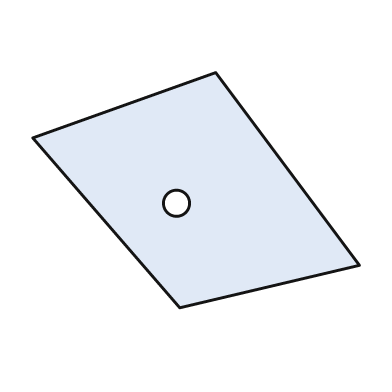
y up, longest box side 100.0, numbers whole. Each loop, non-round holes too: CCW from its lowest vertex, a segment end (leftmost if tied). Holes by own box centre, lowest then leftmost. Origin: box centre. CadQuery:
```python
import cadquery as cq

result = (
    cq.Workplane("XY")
    .moveTo(-5.0, -36.0)
    .lineTo(50.0, -23.0)
    .lineTo(6.0, 36.0)
    .lineTo(-50.0, 16.0)
    .close()
    .moveTo(-6.0, -4.0)
    .circle(4.0)
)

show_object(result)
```